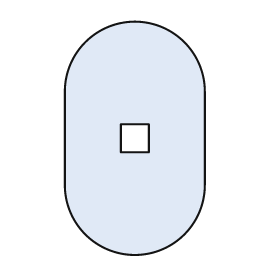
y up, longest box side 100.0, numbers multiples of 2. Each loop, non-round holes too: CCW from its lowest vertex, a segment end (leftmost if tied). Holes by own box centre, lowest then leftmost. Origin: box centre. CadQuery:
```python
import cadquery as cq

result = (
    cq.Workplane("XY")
    .moveTo(-30.0, -20.0)
    .threePointArc((0.0, -50.0), (30.0, -20.0))
    .lineTo(30.0, 20.0)
    .threePointArc((0.0, 50.0), (-30.0, 20.0))
    .close()
    .moveTo(-6.0, -6.0)
    .lineTo(6.0, -6.0)
    .lineTo(6.0, 6.0)
    .lineTo(-6.0, 6.0)
    .close()
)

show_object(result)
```